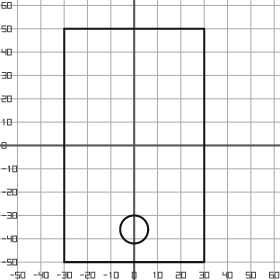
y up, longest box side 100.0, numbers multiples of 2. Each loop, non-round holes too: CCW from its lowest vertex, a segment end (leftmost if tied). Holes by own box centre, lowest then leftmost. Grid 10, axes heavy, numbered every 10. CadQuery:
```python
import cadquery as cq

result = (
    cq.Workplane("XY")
    .moveTo(-30.0, -50.0)
    .lineTo(30.0, -50.0)
    .lineTo(30.0, 50.0)
    .lineTo(-30.0, 50.0)
    .close()
    .moveTo(0.0, -36.0)
    .circle(6.0)
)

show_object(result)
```